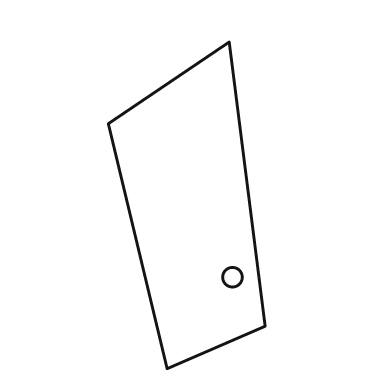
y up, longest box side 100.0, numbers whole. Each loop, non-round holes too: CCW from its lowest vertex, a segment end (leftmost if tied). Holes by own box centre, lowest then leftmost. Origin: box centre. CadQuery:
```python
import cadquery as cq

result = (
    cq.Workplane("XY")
    .moveTo(-6.0, -50.0)
    .lineTo(24.0, -37.0)
    .lineTo(13.0, 50.0)
    .lineTo(-24.0, 25.0)
    .close()
    .moveTo(14.0, -22.0)
    .circle(3.0)
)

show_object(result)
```